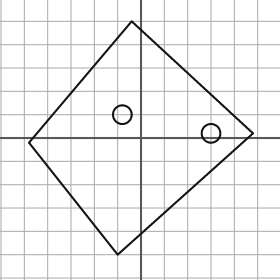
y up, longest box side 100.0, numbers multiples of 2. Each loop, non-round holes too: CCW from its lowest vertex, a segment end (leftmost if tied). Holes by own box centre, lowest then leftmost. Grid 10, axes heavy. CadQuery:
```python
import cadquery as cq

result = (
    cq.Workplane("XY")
    .moveTo(-10.0, -50.0)
    .lineTo(48.0, 2.0)
    .lineTo(-4.0, 50.0)
    .lineTo(-48.0, -2.0)
    .close()
    .moveTo(30.0, 2.0)
    .circle(4.0)
    .moveTo(-8.0, 10.0)
    .circle(4.0)
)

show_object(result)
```